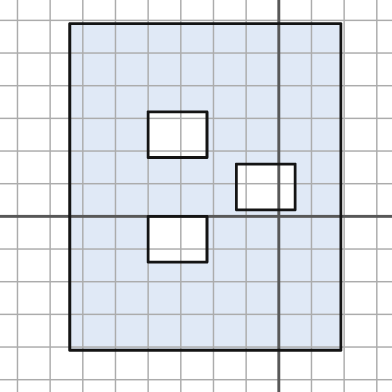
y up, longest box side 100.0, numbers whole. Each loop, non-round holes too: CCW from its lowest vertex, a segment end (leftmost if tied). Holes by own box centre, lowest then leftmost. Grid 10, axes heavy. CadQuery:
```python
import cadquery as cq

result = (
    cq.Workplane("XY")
    .moveTo(-64.0, -41.0)
    .lineTo(19.0, -41.0)
    .lineTo(19.0, 59.0)
    .lineTo(-64.0, 59.0)
    .close()
    .moveTo(-40.0, -14.0)
    .lineTo(-22.0, -14.0)
    .lineTo(-22.0, 0.0)
    .lineTo(-40.0, 0.0)
    .close()
    .moveTo(-13.0, 2.0)
    .lineTo(5.0, 2.0)
    .lineTo(5.0, 16.0)
    .lineTo(-13.0, 16.0)
    .close()
    .moveTo(-40.0, 18.0)
    .lineTo(-22.0, 18.0)
    .lineTo(-22.0, 32.0)
    .lineTo(-40.0, 32.0)
    .close()
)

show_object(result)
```